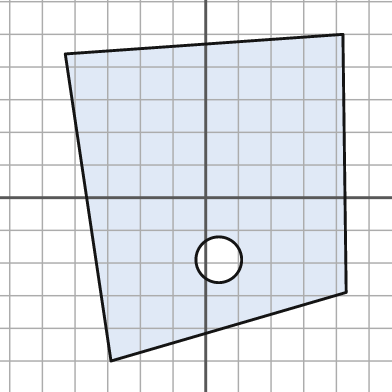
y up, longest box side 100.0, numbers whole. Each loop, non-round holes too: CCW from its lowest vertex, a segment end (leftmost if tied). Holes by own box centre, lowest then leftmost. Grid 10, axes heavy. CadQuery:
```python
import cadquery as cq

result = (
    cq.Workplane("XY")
    .moveTo(-29.0, -50.0)
    .lineTo(43.0, -29.0)
    .lineTo(42.0, 50.0)
    .lineTo(-43.0, 44.0)
    .close()
    .moveTo(4.0, -19.0)
    .circle(7.0)
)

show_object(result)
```